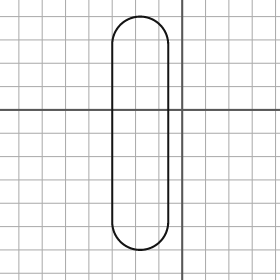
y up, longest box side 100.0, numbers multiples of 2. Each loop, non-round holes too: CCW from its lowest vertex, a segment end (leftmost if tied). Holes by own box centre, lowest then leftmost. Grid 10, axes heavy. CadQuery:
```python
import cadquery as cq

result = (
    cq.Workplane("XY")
    .moveTo(-30.0, -48.0)
    .threePointArc((-18.0, -60.0), (-6.0, -48.0))
    .lineTo(-6.0, 28.0)
    .threePointArc((-18.0, 40.0), (-30.0, 28.0))
    .close()
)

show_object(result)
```